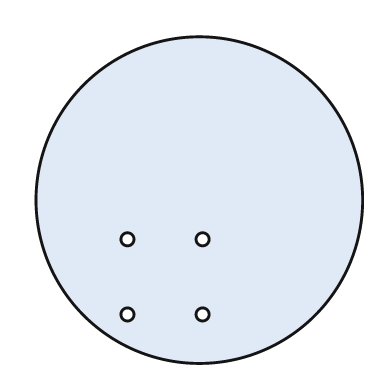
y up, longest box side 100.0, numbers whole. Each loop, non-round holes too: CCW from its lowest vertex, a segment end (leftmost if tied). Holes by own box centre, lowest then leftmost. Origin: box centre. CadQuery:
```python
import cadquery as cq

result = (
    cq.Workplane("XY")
    .moveTo(0.0, 0.0)
    .circle(50.0)
    .moveTo(-22.0, -35.0)
    .circle(2.0)
    .moveTo(1.0, -35.0)
    .circle(2.0)
    .moveTo(-22.0, -12.0)
    .circle(2.0)
    .moveTo(1.0, -12.0)
    .circle(2.0)
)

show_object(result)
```